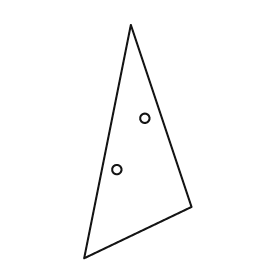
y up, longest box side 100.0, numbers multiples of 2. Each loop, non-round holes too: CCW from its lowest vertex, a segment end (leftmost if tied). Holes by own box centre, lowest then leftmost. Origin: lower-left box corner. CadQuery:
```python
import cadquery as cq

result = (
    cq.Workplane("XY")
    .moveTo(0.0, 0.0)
    .lineTo(46.0, 22.0)
    .lineTo(20.0, 100.0)
    .close()
    .moveTo(14.0, 38.0)
    .circle(2.0)
    .moveTo(26.0, 60.0)
    .circle(2.0)
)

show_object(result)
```